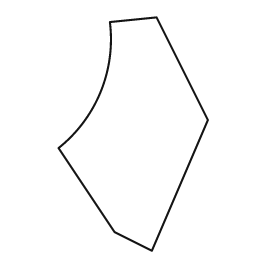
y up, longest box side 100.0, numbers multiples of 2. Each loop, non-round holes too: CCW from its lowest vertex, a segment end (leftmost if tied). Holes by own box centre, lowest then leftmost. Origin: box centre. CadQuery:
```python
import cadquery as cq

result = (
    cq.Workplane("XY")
    .moveTo(8.0, -50.0)
    .lineTo(32.0, 6.0)
    .lineTo(10.0, 50.0)
    .lineTo(-10.0, 48.0)
    .threePointArc((-14.0, 18.0), (-32.0, -6.0))
    .lineTo(-8.0, -42.0)
    .close()
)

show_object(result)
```